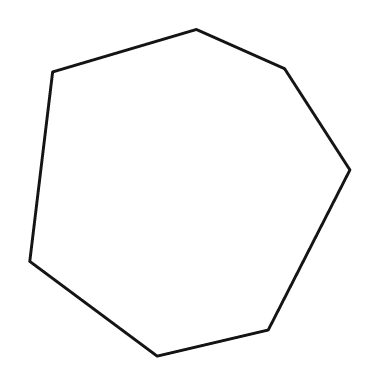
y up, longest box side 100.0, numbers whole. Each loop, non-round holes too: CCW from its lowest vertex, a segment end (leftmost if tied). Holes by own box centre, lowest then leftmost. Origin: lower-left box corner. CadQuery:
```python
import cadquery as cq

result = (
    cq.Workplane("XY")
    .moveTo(39.0, 0.0)
    .lineTo(73.0, 8.0)
    .lineTo(98.0, 57.0)
    .lineTo(78.0, 88.0)
    .lineTo(51.0, 100.0)
    .lineTo(7.0, 87.0)
    .lineTo(0.0, 29.0)
    .close()
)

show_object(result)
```